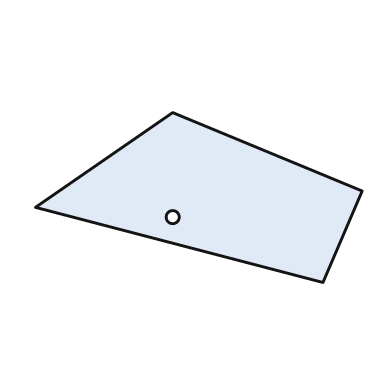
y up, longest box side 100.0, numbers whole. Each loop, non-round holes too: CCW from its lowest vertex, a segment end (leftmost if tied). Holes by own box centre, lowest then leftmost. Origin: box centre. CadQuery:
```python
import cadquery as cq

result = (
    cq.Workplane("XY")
    .moveTo(38.0, -26.0)
    .lineTo(50.0, 2.0)
    .lineTo(-8.0, 26.0)
    .lineTo(-50.0, -3.0)
    .close()
    .moveTo(-8.0, -6.0)
    .circle(2.0)
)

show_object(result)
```